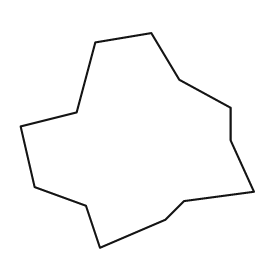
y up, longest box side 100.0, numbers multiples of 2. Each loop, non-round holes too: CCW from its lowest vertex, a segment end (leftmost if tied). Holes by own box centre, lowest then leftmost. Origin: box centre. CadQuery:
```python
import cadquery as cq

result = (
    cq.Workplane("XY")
    .moveTo(-16.0, -46.0)
    .lineTo(12.0, -34.0)
    .lineTo(20.0, -26.0)
    .lineTo(50.0, -22.0)
    .lineTo(40.0, 0.0)
    .lineTo(40.0, 14.0)
    .lineTo(18.0, 26.0)
    .lineTo(6.0, 46.0)
    .lineTo(-18.0, 42.0)
    .lineTo(-26.0, 12.0)
    .lineTo(-50.0, 6.0)
    .lineTo(-44.0, -20.0)
    .lineTo(-22.0, -28.0)
    .close()
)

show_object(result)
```